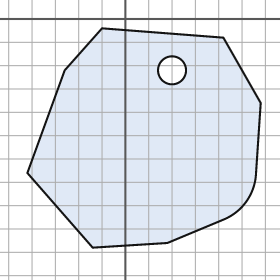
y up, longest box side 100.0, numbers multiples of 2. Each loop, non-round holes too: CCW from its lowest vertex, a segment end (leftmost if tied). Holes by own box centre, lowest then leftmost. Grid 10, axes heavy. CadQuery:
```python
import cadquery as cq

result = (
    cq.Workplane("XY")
    .moveTo(-14.0, -98.0)
    .lineTo(18.0, -96.0)
    .lineTo(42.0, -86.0)
    .threePointArc((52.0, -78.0), (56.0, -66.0))
    .lineTo(58.0, -36.0)
    .lineTo(42.0, -8.0)
    .lineTo(-10.0, -4.0)
    .lineTo(-26.0, -22.0)
    .lineTo(-42.0, -66.0)
    .close()
    .moveTo(20.0, -22.0)
    .circle(6.0)
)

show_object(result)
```